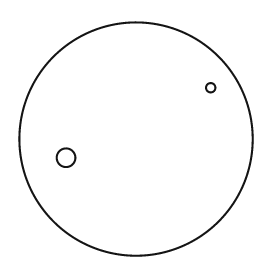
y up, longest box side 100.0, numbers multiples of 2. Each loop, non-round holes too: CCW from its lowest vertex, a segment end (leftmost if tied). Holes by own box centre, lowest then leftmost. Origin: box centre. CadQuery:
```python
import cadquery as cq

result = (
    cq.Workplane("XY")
    .moveTo(0.0, 0.0)
    .circle(50.0)
    .moveTo(-30.0, -8.0)
    .circle(4.0)
    .moveTo(32.0, 22.0)
    .circle(2.0)
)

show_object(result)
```